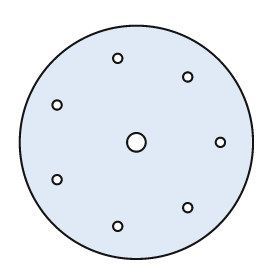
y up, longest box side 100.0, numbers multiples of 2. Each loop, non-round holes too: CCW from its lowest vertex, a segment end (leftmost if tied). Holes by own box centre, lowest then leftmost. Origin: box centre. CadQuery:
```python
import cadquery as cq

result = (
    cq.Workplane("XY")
    .moveTo(0.0, 0.0)
    .circle(50.0)
    .moveTo(-8.0, -36.0)
    .circle(2.0)
    .moveTo(22.0, -28.0)
    .circle(2.0)
    .moveTo(-34.0, -16.0)
    .circle(2.0)
    .moveTo(0.0, 0.0)
    .circle(4.0)
    .moveTo(36.0, 0.0)
    .circle(2.0)
    .moveTo(-34.0, 16.0)
    .circle(2.0)
    .moveTo(22.0, 28.0)
    .circle(2.0)
    .moveTo(-8.0, 36.0)
    .circle(2.0)
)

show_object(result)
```